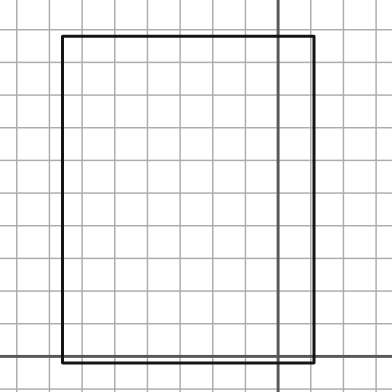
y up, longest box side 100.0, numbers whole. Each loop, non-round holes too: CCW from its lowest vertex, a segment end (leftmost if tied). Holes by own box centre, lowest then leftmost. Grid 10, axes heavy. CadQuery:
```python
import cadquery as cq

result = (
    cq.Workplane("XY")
    .moveTo(-66.0, -2.0)
    .lineTo(11.0, -2.0)
    .lineTo(11.0, 98.0)
    .lineTo(-66.0, 98.0)
    .close()
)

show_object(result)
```